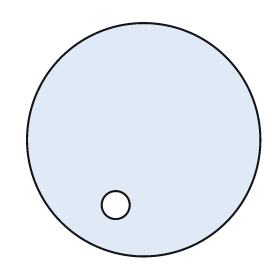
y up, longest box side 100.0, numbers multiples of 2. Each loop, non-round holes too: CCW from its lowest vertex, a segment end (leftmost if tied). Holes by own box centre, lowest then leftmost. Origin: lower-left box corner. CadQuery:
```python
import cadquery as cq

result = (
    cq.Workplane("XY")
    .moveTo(50.0, 50.0)
    .circle(50.0)
    .moveTo(38.0, 22.0)
    .circle(6.0)
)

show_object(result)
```